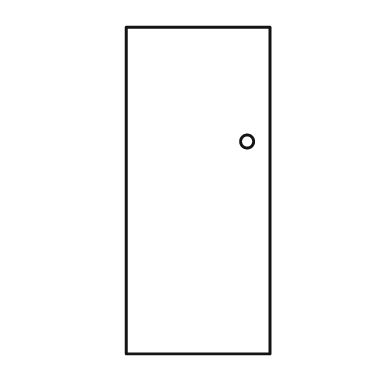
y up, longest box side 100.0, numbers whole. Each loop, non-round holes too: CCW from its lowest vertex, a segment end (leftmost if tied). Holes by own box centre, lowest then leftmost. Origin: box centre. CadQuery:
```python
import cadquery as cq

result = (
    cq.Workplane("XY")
    .moveTo(-22.0, -50.0)
    .lineTo(22.0, -50.0)
    .lineTo(22.0, 50.0)
    .lineTo(-22.0, 50.0)
    .close()
    .moveTo(15.0, 15.0)
    .circle(2.0)
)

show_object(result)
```